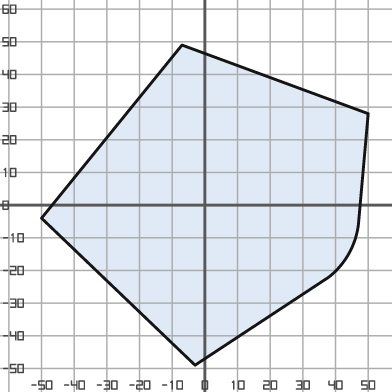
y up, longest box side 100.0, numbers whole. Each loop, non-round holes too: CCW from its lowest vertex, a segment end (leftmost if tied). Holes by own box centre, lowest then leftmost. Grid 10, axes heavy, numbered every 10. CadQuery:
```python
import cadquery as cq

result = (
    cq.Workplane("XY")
    .moveTo(-3.0, -49.0)
    .lineTo(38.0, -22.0)
    .threePointArc((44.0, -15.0), (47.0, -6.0))
    .lineTo(50.0, 28.0)
    .lineTo(-7.0, 49.0)
    .lineTo(-50.0, -4.0)
    .close()
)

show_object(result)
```